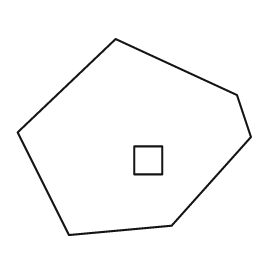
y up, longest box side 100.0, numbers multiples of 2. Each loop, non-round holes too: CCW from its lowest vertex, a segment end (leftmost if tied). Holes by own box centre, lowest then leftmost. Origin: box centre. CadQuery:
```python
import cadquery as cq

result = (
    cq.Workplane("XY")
    .moveTo(-28.0, -42.0)
    .lineTo(16.0, -38.0)
    .lineTo(50.0, 0.0)
    .lineTo(44.0, 18.0)
    .lineTo(-8.0, 42.0)
    .lineTo(-50.0, 2.0)
    .close()
    .moveTo(0.0, -16.0)
    .lineTo(12.0, -16.0)
    .lineTo(12.0, -4.0)
    .lineTo(0.0, -4.0)
    .close()
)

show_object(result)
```